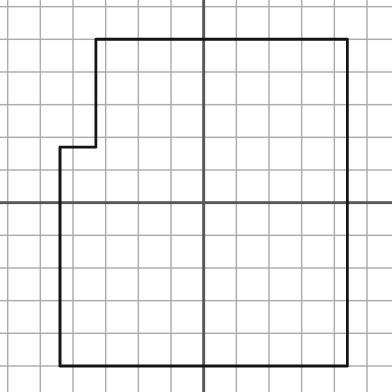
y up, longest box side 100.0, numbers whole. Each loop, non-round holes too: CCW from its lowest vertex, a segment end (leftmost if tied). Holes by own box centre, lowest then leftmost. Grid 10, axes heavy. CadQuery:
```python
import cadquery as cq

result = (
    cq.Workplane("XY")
    .moveTo(-44.0, -50.0)
    .lineTo(44.0, -50.0)
    .lineTo(44.0, 50.0)
    .lineTo(-33.0, 50.0)
    .lineTo(-33.0, 17.0)
    .lineTo(-44.0, 17.0)
    .close()
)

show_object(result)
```